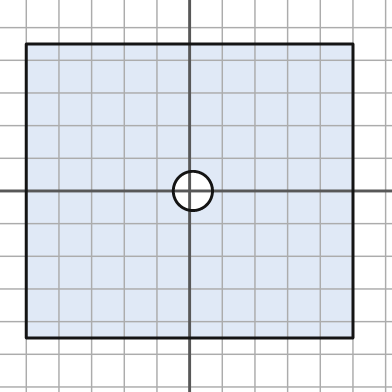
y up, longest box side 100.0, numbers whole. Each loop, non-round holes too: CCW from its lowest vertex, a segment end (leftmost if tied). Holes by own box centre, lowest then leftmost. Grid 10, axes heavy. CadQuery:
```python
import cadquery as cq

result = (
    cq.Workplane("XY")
    .moveTo(-50.0, -45.0)
    .lineTo(50.0, -45.0)
    .lineTo(50.0, 45.0)
    .lineTo(-50.0, 45.0)
    .close()
    .moveTo(1.0, 0.0)
    .circle(6.0)
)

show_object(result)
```